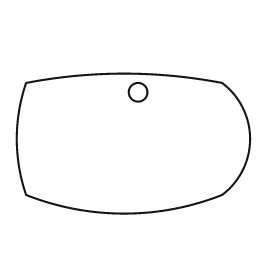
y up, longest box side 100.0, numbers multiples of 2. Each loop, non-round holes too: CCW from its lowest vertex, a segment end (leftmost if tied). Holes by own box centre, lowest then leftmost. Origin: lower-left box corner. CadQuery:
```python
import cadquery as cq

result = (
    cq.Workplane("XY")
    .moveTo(4.0, 8.0)
    .threePointArc((46.0, 0.0), (88.0, 8.0))
    .threePointArc((100.0, 32.0), (88.0, 56.0))
    .threePointArc((46.0, 60.0), (4.0, 56.0))
    .threePointArc((0.0, 32.0), (4.0, 8.0))
    .close()
    .moveTo(52.0, 52.0)
    .circle(4.0)
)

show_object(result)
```